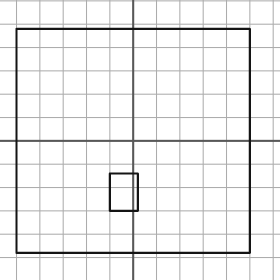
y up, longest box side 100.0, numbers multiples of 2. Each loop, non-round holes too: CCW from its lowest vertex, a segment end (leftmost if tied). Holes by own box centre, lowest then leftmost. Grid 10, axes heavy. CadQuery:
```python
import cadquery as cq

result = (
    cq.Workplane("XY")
    .moveTo(-50.0, -48.0)
    .lineTo(50.0, -48.0)
    .lineTo(50.0, 48.0)
    .lineTo(-50.0, 48.0)
    .close()
    .moveTo(-10.0, -30.0)
    .lineTo(2.0, -30.0)
    .lineTo(2.0, -14.0)
    .lineTo(-10.0, -14.0)
    .close()
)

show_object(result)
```